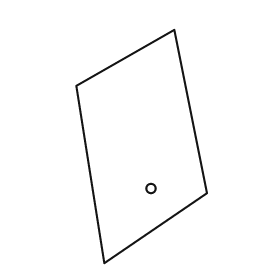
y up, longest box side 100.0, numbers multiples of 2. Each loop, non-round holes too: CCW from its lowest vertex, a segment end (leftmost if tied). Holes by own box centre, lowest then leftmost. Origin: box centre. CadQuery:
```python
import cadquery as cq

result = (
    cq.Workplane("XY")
    .moveTo(-16.0, -50.0)
    .lineTo(28.0, -20.0)
    .lineTo(14.0, 50.0)
    .lineTo(-28.0, 26.0)
    .close()
    .moveTo(4.0, -18.0)
    .circle(2.0)
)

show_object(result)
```